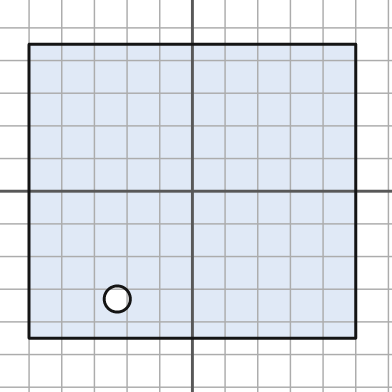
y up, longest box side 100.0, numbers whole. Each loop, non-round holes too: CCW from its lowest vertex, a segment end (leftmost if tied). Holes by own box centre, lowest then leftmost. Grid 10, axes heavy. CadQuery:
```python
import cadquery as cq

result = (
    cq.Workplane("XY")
    .moveTo(-50.0, -45.0)
    .lineTo(50.0, -45.0)
    .lineTo(50.0, 45.0)
    .lineTo(-50.0, 45.0)
    .close()
    .moveTo(-23.0, -33.0)
    .circle(4.0)
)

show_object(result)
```